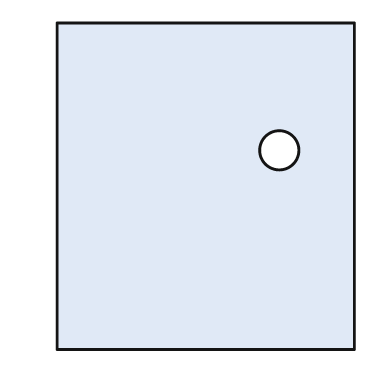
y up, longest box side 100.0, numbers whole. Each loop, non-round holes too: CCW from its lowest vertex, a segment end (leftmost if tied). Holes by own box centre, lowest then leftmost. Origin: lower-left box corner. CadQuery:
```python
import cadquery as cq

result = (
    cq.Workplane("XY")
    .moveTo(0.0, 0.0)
    .lineTo(91.0, 0.0)
    .lineTo(91.0, 100.0)
    .lineTo(0.0, 100.0)
    .close()
    .moveTo(68.0, 61.0)
    .circle(6.0)
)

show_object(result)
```